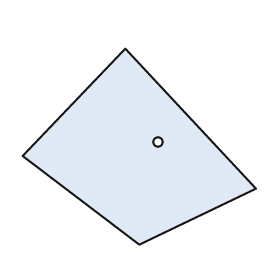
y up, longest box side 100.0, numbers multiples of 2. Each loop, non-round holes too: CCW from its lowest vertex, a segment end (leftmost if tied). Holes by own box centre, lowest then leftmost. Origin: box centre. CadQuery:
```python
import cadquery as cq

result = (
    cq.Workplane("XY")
    .moveTo(0.0, -42.0)
    .lineTo(50.0, -18.0)
    .lineTo(-6.0, 42.0)
    .lineTo(-50.0, -4.0)
    .close()
    .moveTo(8.0, 2.0)
    .circle(2.0)
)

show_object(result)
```